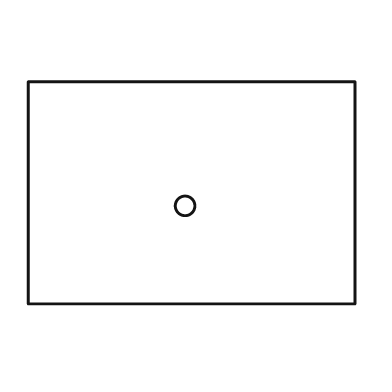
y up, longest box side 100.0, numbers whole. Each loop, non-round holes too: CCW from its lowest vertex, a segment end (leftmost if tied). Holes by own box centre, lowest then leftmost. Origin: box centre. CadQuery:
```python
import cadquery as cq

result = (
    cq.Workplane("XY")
    .moveTo(-50.0, -34.0)
    .lineTo(50.0, -34.0)
    .lineTo(50.0, 34.0)
    .lineTo(-50.0, 34.0)
    .close()
    .moveTo(-2.0, -4.0)
    .circle(3.0)
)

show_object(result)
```